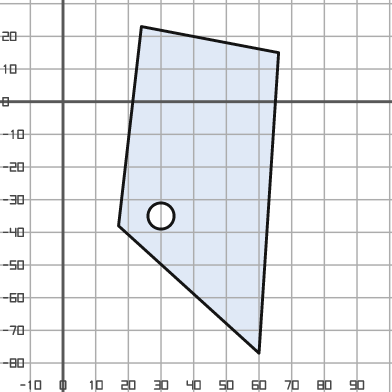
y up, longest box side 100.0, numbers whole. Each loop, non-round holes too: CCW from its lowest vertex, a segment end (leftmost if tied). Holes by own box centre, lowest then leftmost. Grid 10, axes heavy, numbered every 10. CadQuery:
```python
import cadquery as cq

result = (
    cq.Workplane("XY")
    .moveTo(60.0, -77.0)
    .lineTo(66.0, 15.0)
    .lineTo(24.0, 23.0)
    .lineTo(17.0, -38.0)
    .close()
    .moveTo(30.0, -35.0)
    .circle(4.0)
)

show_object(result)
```